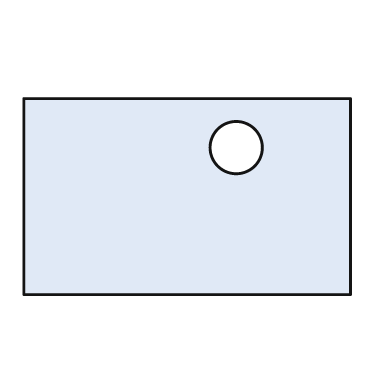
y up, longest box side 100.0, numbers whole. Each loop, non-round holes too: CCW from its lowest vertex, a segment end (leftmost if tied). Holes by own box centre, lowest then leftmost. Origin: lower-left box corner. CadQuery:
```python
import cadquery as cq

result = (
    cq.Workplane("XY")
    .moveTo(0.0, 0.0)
    .lineTo(100.0, 0.0)
    .lineTo(100.0, 60.0)
    .lineTo(0.0, 60.0)
    .close()
    .moveTo(65.0, 45.0)
    .circle(8.0)
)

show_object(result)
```